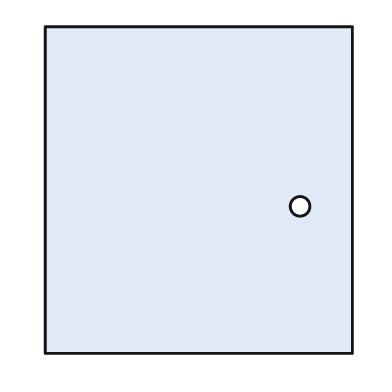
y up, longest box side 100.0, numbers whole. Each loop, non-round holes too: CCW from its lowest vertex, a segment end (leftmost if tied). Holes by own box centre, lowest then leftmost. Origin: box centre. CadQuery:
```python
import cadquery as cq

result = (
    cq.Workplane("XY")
    .moveTo(-47.0, -50.0)
    .lineTo(47.0, -50.0)
    .lineTo(47.0, 50.0)
    .lineTo(-47.0, 50.0)
    .close()
    .moveTo(31.0, -5.0)
    .circle(3.0)
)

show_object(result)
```